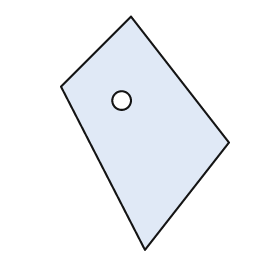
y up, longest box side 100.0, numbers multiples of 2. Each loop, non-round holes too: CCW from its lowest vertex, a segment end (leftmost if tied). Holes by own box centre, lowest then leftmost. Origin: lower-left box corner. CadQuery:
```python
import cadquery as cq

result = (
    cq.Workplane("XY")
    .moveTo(36.0, 0.0)
    .lineTo(72.0, 46.0)
    .lineTo(30.0, 100.0)
    .lineTo(0.0, 70.0)
    .close()
    .moveTo(26.0, 64.0)
    .circle(4.0)
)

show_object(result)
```